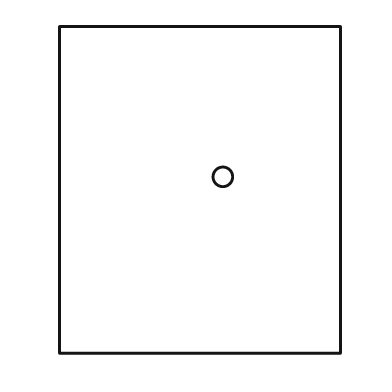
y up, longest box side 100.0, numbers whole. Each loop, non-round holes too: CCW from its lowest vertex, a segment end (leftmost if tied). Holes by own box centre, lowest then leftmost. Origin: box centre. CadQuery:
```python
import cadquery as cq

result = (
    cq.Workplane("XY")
    .moveTo(-43.0, -50.0)
    .lineTo(43.0, -50.0)
    .lineTo(43.0, 50.0)
    .lineTo(-43.0, 50.0)
    .close()
    .moveTo(7.0, 4.0)
    .circle(3.0)
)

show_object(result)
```